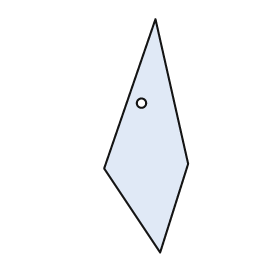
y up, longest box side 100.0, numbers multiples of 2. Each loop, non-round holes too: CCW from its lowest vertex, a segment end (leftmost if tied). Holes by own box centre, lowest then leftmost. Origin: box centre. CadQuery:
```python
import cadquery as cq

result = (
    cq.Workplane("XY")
    .moveTo(6.0, -50.0)
    .lineTo(18.0, -12.0)
    .lineTo(4.0, 50.0)
    .lineTo(-18.0, -14.0)
    .close()
    .moveTo(-2.0, 14.0)
    .circle(2.0)
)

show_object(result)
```